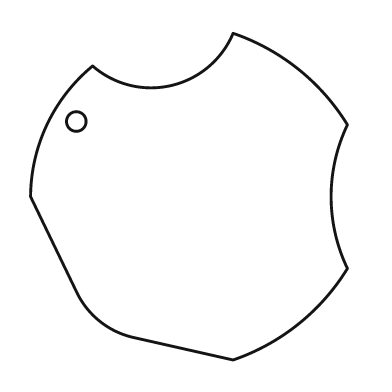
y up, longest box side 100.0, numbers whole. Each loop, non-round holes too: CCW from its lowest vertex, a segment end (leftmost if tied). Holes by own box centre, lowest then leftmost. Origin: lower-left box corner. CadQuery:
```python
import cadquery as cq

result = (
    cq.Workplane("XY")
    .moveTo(62.0, 0.0)
    .threePointArc((82.0, 11.0), (97.0, 28.0))
    .threePointArc((92.0, 50.0), (97.0, 72.0))
    .threePointArc((82.0, 89.0), (62.0, 100.0))
    .threePointArc((43.0, 84.0), (19.0, 90.0))
    .threePointArc((5.0, 72.0), (0.0, 50.0))
    .lineTo(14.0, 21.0)
    .threePointArc((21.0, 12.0), (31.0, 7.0))
    .close()
    .moveTo(14.0, 73.0)
    .circle(3.0)
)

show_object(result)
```